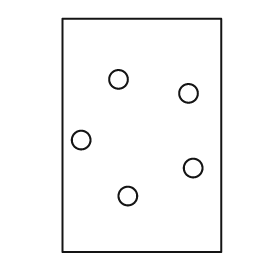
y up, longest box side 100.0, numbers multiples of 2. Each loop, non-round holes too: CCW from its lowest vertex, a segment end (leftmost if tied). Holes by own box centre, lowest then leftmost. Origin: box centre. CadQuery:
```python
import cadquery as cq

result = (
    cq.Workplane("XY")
    .moveTo(-34.0, -50.0)
    .lineTo(34.0, -50.0)
    .lineTo(34.0, 50.0)
    .lineTo(-34.0, 50.0)
    .close()
    .moveTo(-6.0, -26.0)
    .circle(4.0)
    .moveTo(22.0, -14.0)
    .circle(4.0)
    .moveTo(-26.0, -2.0)
    .circle(4.0)
    .moveTo(20.0, 18.0)
    .circle(4.0)
    .moveTo(-10.0, 24.0)
    .circle(4.0)
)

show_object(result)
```